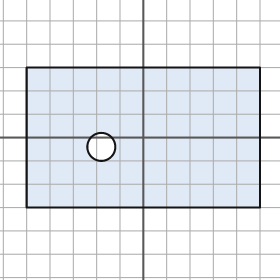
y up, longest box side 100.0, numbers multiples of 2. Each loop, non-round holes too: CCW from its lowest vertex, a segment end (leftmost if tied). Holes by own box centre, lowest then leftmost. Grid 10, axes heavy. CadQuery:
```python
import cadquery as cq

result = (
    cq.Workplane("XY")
    .moveTo(-50.0, -30.0)
    .lineTo(50.0, -30.0)
    .lineTo(50.0, 30.0)
    .lineTo(-50.0, 30.0)
    .close()
    .moveTo(-18.0, -4.0)
    .circle(6.0)
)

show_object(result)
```